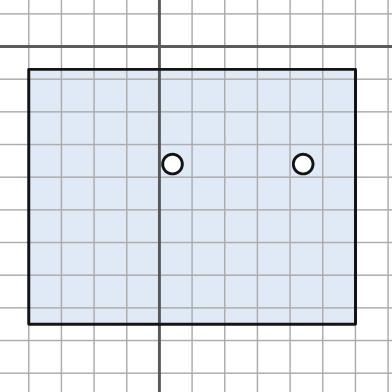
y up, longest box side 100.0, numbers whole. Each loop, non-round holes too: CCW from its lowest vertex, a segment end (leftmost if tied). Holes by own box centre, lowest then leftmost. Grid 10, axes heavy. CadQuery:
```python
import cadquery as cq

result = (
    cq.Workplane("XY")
    .moveTo(-40.0, -85.0)
    .lineTo(60.0, -85.0)
    .lineTo(60.0, -7.0)
    .lineTo(-40.0, -7.0)
    .close()
    .moveTo(4.0, -36.0)
    .circle(3.0)
    .moveTo(44.0, -36.0)
    .circle(3.0)
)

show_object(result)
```